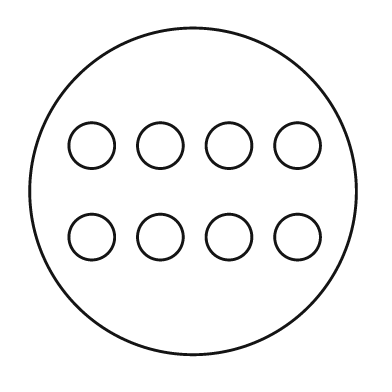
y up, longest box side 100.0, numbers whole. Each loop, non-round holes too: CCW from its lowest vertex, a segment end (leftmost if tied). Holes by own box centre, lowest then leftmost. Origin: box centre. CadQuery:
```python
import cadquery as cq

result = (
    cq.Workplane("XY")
    .moveTo(0.0, 0.0)
    .circle(50.0)
    .moveTo(-31.0, -14.0)
    .circle(7.0)
    .moveTo(-10.0, -14.0)
    .circle(7.0)
    .moveTo(11.0, -14.0)
    .circle(7.0)
    .moveTo(32.0, -14.0)
    .circle(7.0)
    .moveTo(-31.0, 14.0)
    .circle(7.0)
    .moveTo(-10.0, 14.0)
    .circle(7.0)
    .moveTo(11.0, 14.0)
    .circle(7.0)
    .moveTo(32.0, 14.0)
    .circle(7.0)
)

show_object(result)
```